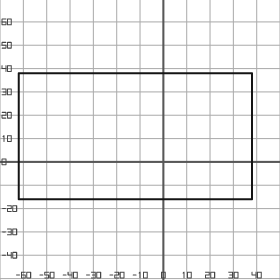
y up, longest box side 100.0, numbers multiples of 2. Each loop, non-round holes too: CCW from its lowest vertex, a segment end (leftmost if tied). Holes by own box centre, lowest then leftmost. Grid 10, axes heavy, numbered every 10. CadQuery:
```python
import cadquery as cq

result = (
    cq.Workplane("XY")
    .moveTo(-62.0, -16.0)
    .lineTo(38.0, -16.0)
    .lineTo(38.0, 38.0)
    .lineTo(-62.0, 38.0)
    .close()
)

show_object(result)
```